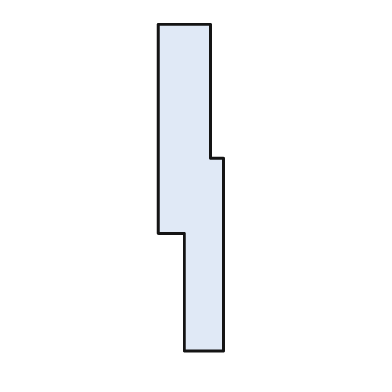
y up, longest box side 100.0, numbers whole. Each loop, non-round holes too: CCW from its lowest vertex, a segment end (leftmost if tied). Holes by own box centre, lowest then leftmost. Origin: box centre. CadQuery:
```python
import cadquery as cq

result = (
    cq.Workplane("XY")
    .moveTo(-2.0, -50.0)
    .lineTo(10.0, -50.0)
    .lineTo(10.0, 9.0)
    .lineTo(6.0, 9.0)
    .lineTo(6.0, 50.0)
    .lineTo(-10.0, 50.0)
    .lineTo(-10.0, -14.0)
    .lineTo(-2.0, -14.0)
    .close()
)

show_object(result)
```